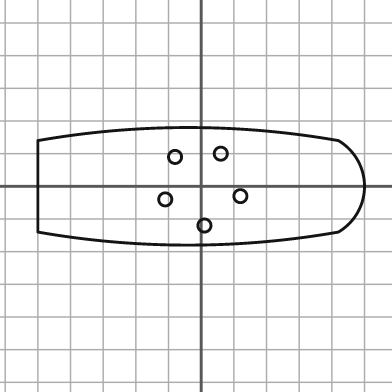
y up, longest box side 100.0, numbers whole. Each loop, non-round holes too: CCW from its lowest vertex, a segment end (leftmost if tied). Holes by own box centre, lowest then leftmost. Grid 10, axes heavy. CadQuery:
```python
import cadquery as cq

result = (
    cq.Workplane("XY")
    .moveTo(-50.0, -14.0)
    .threePointArc((-4.0, -18.0), (42.0, -14.0))
    .threePointArc((50.0, 0.0), (42.0, 14.0))
    .threePointArc((-4.0, 18.0), (-50.0, 14.0))
    .close()
    .moveTo(1.0, -12.0)
    .circle(2.0)
    .moveTo(-11.0, -4.0)
    .circle(2.0)
    .moveTo(12.0, -3.0)
    .circle(2.0)
    .moveTo(-8.0, 9.0)
    .circle(2.0)
    .moveTo(6.0, 10.0)
    .circle(2.0)
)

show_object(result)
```